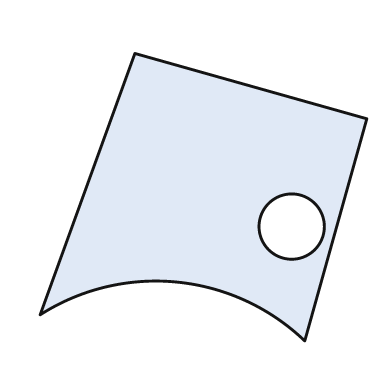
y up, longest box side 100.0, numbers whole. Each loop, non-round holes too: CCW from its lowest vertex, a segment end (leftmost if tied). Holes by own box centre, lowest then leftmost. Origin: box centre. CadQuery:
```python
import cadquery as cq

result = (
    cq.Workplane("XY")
    .moveTo(31.0, -44.0)
    .lineTo(50.0, 24.0)
    .lineTo(-21.0, 44.0)
    .lineTo(-50.0, -36.0)
    .threePointArc((-8.0, -26.0), (31.0, -44.0))
    .close()
    .moveTo(27.0, -9.0)
    .circle(10.0)
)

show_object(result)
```